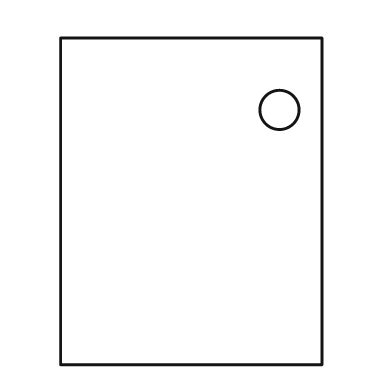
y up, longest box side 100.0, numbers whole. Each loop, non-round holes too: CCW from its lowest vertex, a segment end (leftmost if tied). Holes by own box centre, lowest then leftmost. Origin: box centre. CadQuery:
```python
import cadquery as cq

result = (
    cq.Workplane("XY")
    .moveTo(-40.0, -50.0)
    .lineTo(40.0, -50.0)
    .lineTo(40.0, 50.0)
    .lineTo(-40.0, 50.0)
    .close()
    .moveTo(27.0, 28.0)
    .circle(6.0)
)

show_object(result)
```